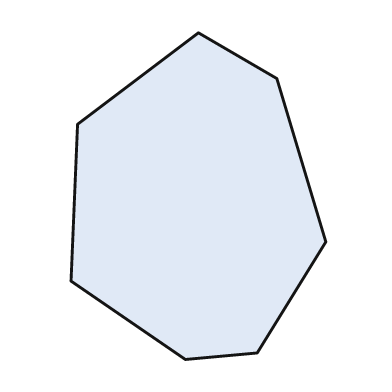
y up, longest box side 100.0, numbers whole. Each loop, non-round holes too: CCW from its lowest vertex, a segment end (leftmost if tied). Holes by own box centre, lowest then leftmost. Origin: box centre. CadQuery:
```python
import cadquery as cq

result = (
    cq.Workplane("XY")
    .moveTo(-4.0, -50.0)
    .lineTo(18.0, -48.0)
    .lineTo(39.0, -14.0)
    .lineTo(24.0, 36.0)
    .lineTo(0.0, 50.0)
    .lineTo(-37.0, 22.0)
    .lineTo(-39.0, -26.0)
    .close()
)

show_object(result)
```